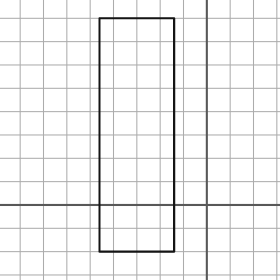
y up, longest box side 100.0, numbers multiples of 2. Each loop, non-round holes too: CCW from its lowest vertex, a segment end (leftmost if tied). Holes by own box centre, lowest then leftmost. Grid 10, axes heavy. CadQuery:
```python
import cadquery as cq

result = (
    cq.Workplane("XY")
    .moveTo(-46.0, -20.0)
    .lineTo(-14.0, -20.0)
    .lineTo(-14.0, 80.0)
    .lineTo(-46.0, 80.0)
    .close()
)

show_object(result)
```